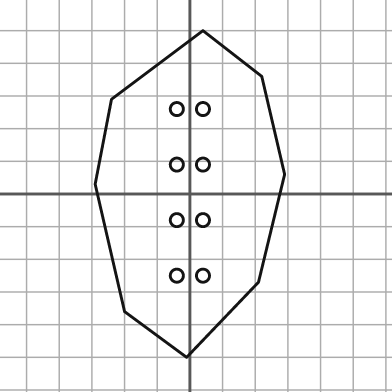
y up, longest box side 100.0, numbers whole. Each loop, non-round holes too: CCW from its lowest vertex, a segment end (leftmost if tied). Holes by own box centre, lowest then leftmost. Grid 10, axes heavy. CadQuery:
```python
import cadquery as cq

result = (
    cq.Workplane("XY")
    .moveTo(-1.0, -50.0)
    .lineTo(21.0, -27.0)
    .lineTo(29.0, 6.0)
    .lineTo(22.0, 36.0)
    .lineTo(4.0, 50.0)
    .lineTo(-24.0, 29.0)
    .lineTo(-29.0, 3.0)
    .lineTo(-20.0, -36.0)
    .close()
    .moveTo(-4.0, -25.0)
    .circle(2.0)
    .moveTo(4.0, -25.0)
    .circle(2.0)
    .moveTo(-4.0, -8.0)
    .circle(2.0)
    .moveTo(4.0, -8.0)
    .circle(2.0)
    .moveTo(-4.0, 9.0)
    .circle(2.0)
    .moveTo(4.0, 9.0)
    .circle(2.0)
    .moveTo(-4.0, 26.0)
    .circle(2.0)
    .moveTo(4.0, 26.0)
    .circle(2.0)
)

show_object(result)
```